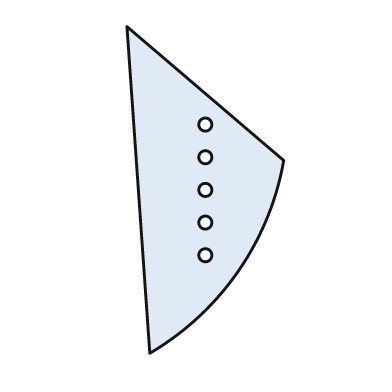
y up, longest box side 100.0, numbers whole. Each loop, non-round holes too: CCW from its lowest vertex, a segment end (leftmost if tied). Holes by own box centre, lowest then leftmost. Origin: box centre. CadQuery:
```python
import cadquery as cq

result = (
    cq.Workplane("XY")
    .moveTo(-17.0, -50.0)
    .threePointArc((10.0, -25.0), (24.0, 9.0))
    .lineTo(-24.0, 50.0)
    .close()
    .moveTo(0.0, -20.0)
    .circle(2.0)
    .moveTo(0.0, -10.0)
    .circle(2.0)
    .moveTo(0.0, 0.0)
    .circle(2.0)
    .moveTo(0.0, 10.0)
    .circle(2.0)
    .moveTo(0.0, 20.0)
    .circle(2.0)
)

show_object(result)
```